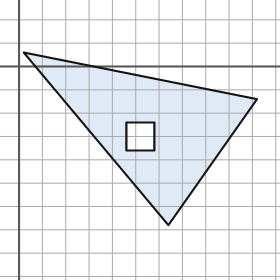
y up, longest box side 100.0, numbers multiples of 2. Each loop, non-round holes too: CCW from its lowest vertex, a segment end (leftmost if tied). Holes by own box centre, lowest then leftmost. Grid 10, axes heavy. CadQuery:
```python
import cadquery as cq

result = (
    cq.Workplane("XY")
    .moveTo(64.0, -68.0)
    .lineTo(102.0, -14.0)
    .lineTo(2.0, 6.0)
    .close()
    .moveTo(46.0, -36.0)
    .lineTo(58.0, -36.0)
    .lineTo(58.0, -24.0)
    .lineTo(46.0, -24.0)
    .close()
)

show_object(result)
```